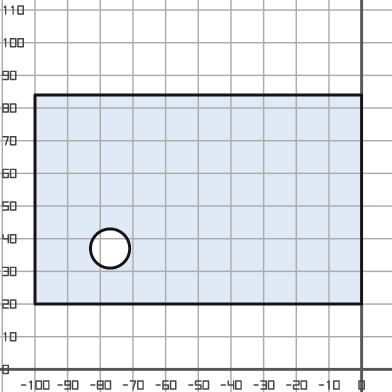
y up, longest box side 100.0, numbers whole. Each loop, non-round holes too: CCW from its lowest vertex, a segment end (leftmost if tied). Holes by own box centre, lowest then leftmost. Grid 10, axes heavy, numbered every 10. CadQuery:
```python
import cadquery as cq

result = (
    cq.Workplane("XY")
    .moveTo(-100.0, 20.0)
    .lineTo(0.0, 20.0)
    .lineTo(0.0, 84.0)
    .lineTo(-100.0, 84.0)
    .close()
    .moveTo(-77.0, 37.0)
    .circle(6.0)
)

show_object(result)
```